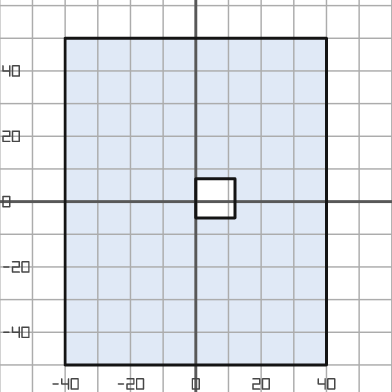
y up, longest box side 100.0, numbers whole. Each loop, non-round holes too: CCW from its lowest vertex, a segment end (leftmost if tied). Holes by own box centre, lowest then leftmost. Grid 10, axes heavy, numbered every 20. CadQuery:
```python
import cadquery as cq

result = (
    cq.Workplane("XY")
    .moveTo(-40.0, -50.0)
    .lineTo(40.0, -50.0)
    .lineTo(40.0, 50.0)
    .lineTo(-40.0, 50.0)
    .close()
    .moveTo(0.0, -5.0)
    .lineTo(12.0, -5.0)
    .lineTo(12.0, 7.0)
    .lineTo(0.0, 7.0)
    .close()
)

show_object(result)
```